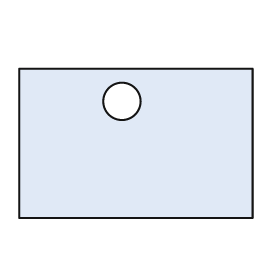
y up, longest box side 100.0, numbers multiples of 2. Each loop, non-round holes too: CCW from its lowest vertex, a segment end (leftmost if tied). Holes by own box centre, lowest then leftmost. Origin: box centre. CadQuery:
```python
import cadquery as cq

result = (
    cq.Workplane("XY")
    .moveTo(-50.0, -32.0)
    .lineTo(50.0, -32.0)
    .lineTo(50.0, 32.0)
    .lineTo(-50.0, 32.0)
    .close()
    .moveTo(-6.0, 18.0)
    .circle(8.0)
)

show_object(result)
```